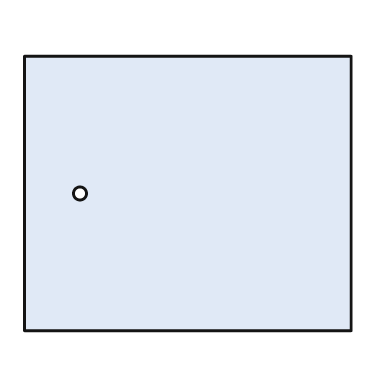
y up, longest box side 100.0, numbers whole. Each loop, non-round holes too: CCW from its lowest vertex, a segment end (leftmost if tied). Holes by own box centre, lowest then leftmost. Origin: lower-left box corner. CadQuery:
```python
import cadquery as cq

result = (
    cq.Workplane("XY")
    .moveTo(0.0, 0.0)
    .lineTo(100.0, 0.0)
    .lineTo(100.0, 84.0)
    .lineTo(0.0, 84.0)
    .close()
    .moveTo(17.0, 42.0)
    .circle(2.0)
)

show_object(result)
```